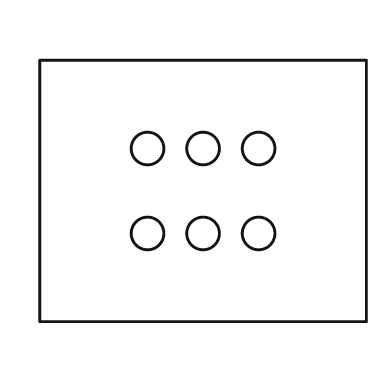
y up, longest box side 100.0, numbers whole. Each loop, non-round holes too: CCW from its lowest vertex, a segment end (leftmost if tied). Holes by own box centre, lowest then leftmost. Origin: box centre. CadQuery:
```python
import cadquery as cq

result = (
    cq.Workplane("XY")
    .moveTo(-50.0, -40.0)
    .lineTo(50.0, -40.0)
    .lineTo(50.0, 40.0)
    .lineTo(-50.0, 40.0)
    .close()
    .moveTo(-17.0, -13.0)
    .circle(5.0)
    .moveTo(0.0, -13.0)
    .circle(5.0)
    .moveTo(17.0, -13.0)
    .circle(5.0)
    .moveTo(-17.0, 13.0)
    .circle(5.0)
    .moveTo(0.0, 13.0)
    .circle(5.0)
    .moveTo(17.0, 13.0)
    .circle(5.0)
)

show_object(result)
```